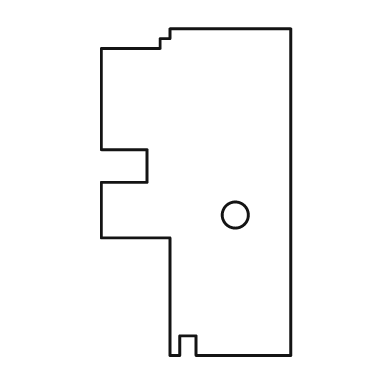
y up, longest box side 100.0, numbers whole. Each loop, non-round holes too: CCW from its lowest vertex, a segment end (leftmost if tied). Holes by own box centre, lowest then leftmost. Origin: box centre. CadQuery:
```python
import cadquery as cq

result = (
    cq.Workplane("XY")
    .moveTo(-8.0, -50.0)
    .lineTo(-5.0, -50.0)
    .lineTo(-5.0, -44.0)
    .lineTo(0.0, -44.0)
    .lineTo(0.0, -50.0)
    .lineTo(29.0, -50.0)
    .lineTo(29.0, 50.0)
    .lineTo(-8.0, 50.0)
    .lineTo(-8.0, 47.0)
    .lineTo(-11.0, 47.0)
    .lineTo(-11.0, 44.0)
    .lineTo(-29.0, 44.0)
    .lineTo(-29.0, 13.0)
    .lineTo(-15.0, 13.0)
    .lineTo(-15.0, 3.0)
    .lineTo(-29.0, 3.0)
    .lineTo(-29.0, -14.0)
    .lineTo(-8.0, -14.0)
    .close()
    .moveTo(12.0, -7.0)
    .circle(4.0)
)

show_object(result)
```